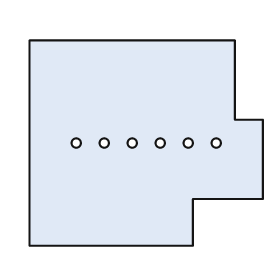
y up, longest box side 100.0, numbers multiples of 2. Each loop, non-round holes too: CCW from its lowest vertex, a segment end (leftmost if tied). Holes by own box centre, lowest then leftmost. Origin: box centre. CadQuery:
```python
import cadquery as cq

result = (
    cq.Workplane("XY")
    .moveTo(-50.0, -44.0)
    .lineTo(20.0, -44.0)
    .lineTo(20.0, -24.0)
    .lineTo(50.0, -24.0)
    .lineTo(50.0, 10.0)
    .lineTo(38.0, 10.0)
    .lineTo(38.0, 44.0)
    .lineTo(-50.0, 44.0)
    .close()
    .moveTo(-30.0, 0.0)
    .circle(2.0)
    .moveTo(-18.0, 0.0)
    .circle(2.0)
    .moveTo(-6.0, 0.0)
    .circle(2.0)
    .moveTo(6.0, 0.0)
    .circle(2.0)
    .moveTo(18.0, 0.0)
    .circle(2.0)
    .moveTo(30.0, 0.0)
    .circle(2.0)
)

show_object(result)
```